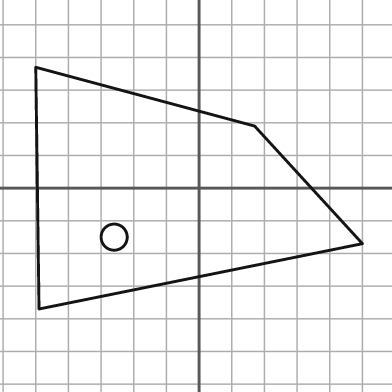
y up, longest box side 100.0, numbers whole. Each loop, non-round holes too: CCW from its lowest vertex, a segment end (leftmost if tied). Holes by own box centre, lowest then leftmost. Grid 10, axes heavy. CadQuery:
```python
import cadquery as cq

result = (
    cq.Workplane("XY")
    .moveTo(-49.0, -37.0)
    .lineTo(50.0, -17.0)
    .lineTo(17.0, 19.0)
    .lineTo(-50.0, 37.0)
    .close()
    .moveTo(-26.0, -15.0)
    .circle(4.0)
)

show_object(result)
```